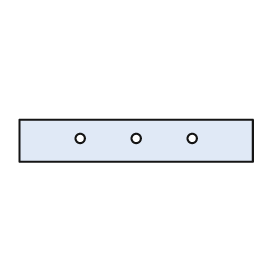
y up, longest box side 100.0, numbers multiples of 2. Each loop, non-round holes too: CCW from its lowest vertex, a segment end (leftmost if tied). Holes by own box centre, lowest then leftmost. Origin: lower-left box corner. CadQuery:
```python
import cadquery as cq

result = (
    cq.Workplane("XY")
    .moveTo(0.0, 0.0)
    .lineTo(100.0, 0.0)
    .lineTo(100.0, 18.0)
    .lineTo(0.0, 18.0)
    .close()
    .moveTo(26.0, 10.0)
    .circle(2.0)
    .moveTo(50.0, 10.0)
    .circle(2.0)
    .moveTo(74.0, 10.0)
    .circle(2.0)
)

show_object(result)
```